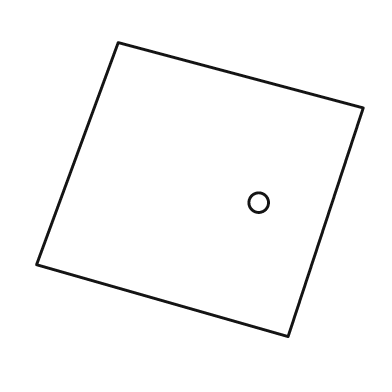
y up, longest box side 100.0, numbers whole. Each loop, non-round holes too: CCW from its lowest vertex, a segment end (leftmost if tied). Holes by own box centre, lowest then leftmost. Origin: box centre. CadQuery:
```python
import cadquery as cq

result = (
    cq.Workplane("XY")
    .moveTo(27.0, -45.0)
    .lineTo(50.0, 25.0)
    .lineTo(-25.0, 45.0)
    .lineTo(-50.0, -23.0)
    .close()
    .moveTo(18.0, -4.0)
    .circle(3.0)
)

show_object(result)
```